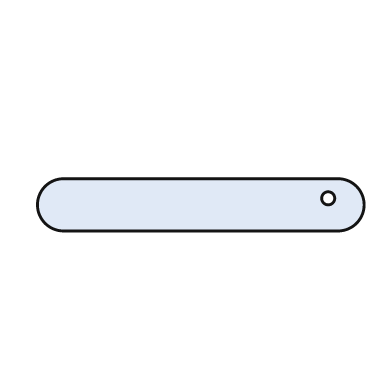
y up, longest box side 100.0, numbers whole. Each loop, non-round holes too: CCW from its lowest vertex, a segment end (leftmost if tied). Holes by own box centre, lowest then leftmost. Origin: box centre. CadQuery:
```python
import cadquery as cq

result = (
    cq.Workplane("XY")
    .moveTo(-42.0, -8.0)
    .lineTo(42.0, -8.0)
    .threePointArc((50.0, 0.0), (42.0, 8.0))
    .lineTo(-42.0, 8.0)
    .threePointArc((-50.0, 0.0), (-42.0, -8.0))
    .close()
    .moveTo(39.0, 2.0)
    .circle(2.0)
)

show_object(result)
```